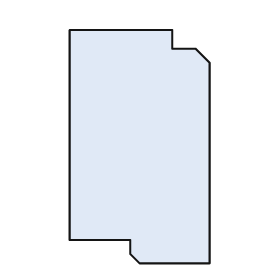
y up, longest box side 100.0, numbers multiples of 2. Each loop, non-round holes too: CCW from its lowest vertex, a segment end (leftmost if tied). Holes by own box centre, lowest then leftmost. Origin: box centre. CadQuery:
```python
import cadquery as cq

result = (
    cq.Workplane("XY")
    .moveTo(0.0, -50.0)
    .lineTo(30.0, -50.0)
    .lineTo(30.0, 36.0)
    .lineTo(24.0, 42.0)
    .lineTo(14.0, 42.0)
    .lineTo(14.0, 50.0)
    .lineTo(-30.0, 50.0)
    .lineTo(-30.0, -40.0)
    .lineTo(-4.0, -40.0)
    .lineTo(-4.0, -46.0)
    .close()
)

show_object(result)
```